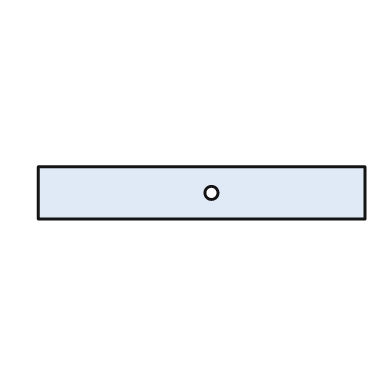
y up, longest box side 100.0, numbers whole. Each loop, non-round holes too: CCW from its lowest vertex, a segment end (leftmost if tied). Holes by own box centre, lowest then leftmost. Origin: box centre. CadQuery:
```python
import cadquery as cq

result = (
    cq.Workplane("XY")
    .moveTo(-50.0, -8.0)
    .lineTo(50.0, -8.0)
    .lineTo(50.0, 8.0)
    .lineTo(-50.0, 8.0)
    .close()
    .moveTo(3.0, 0.0)
    .circle(2.0)
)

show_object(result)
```